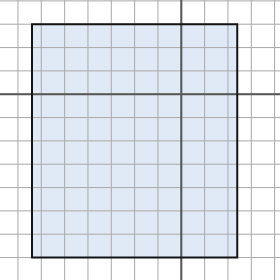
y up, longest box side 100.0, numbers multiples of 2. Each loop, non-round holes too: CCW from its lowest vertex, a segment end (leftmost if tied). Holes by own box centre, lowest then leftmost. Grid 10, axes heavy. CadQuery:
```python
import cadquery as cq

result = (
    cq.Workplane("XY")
    .moveTo(-64.0, -70.0)
    .lineTo(24.0, -70.0)
    .lineTo(24.0, 30.0)
    .lineTo(-64.0, 30.0)
    .close()
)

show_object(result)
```